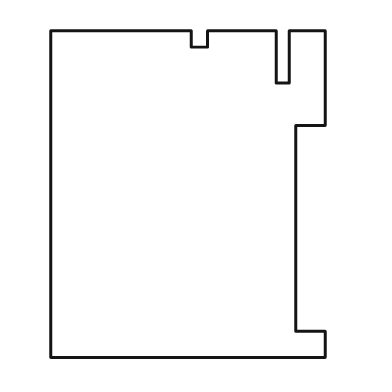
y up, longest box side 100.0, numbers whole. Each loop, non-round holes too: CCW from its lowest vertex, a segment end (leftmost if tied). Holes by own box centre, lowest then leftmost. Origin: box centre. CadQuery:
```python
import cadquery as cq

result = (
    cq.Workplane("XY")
    .moveTo(-42.0, -50.0)
    .lineTo(42.0, -50.0)
    .lineTo(42.0, -42.0)
    .lineTo(33.0, -42.0)
    .lineTo(33.0, 21.0)
    .lineTo(42.0, 21.0)
    .lineTo(42.0, 50.0)
    .lineTo(31.0, 50.0)
    .lineTo(31.0, 34.0)
    .lineTo(27.0, 34.0)
    .lineTo(27.0, 50.0)
    .lineTo(6.0, 50.0)
    .lineTo(6.0, 45.0)
    .lineTo(1.0, 45.0)
    .lineTo(1.0, 50.0)
    .lineTo(-42.0, 50.0)
    .close()
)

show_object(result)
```